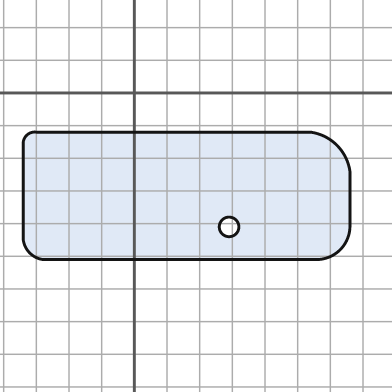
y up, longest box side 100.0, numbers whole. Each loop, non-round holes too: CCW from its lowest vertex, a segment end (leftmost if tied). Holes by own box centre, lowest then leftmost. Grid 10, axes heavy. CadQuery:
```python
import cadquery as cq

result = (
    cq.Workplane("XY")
    .moveTo(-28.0, -51.0)
    .lineTo(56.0, -51.0)
    .threePointArc((63.0, -48.0), (66.0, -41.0))
    .lineTo(66.0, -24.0)
    .threePointArc((62.0, -16.0), (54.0, -12.0))
    .lineTo(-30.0, -12.0)
    .threePointArc((-33.0, -13.0), (-34.0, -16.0))
    .lineTo(-34.0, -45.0)
    .threePointArc((-32.0, -49.0), (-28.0, -51.0))
    .close()
    .moveTo(29.0, -41.0)
    .circle(3.0)
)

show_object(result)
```